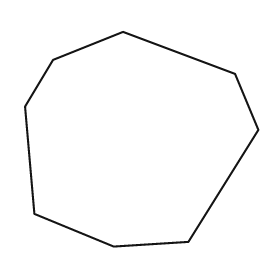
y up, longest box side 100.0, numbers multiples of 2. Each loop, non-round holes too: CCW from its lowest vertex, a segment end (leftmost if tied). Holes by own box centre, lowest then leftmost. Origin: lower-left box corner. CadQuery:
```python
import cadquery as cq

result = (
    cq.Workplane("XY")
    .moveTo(38.0, 0.0)
    .lineTo(70.0, 2.0)
    .lineTo(100.0, 50.0)
    .lineTo(90.0, 74.0)
    .lineTo(42.0, 92.0)
    .lineTo(12.0, 80.0)
    .lineTo(0.0, 60.0)
    .lineTo(4.0, 14.0)
    .close()
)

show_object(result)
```